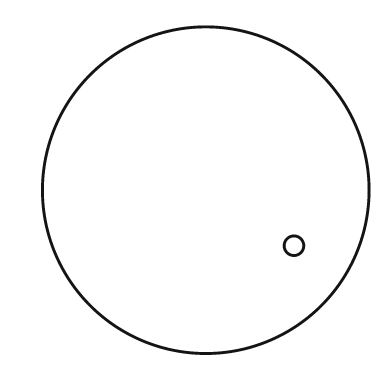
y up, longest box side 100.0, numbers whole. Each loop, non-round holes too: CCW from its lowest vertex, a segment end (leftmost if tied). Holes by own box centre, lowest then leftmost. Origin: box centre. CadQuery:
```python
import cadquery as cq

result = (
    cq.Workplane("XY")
    .moveTo(0.0, 0.0)
    .circle(50.0)
    .moveTo(27.0, -17.0)
    .circle(3.0)
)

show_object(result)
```